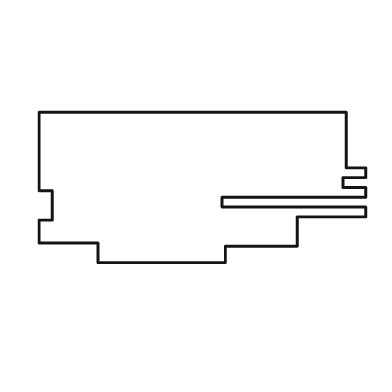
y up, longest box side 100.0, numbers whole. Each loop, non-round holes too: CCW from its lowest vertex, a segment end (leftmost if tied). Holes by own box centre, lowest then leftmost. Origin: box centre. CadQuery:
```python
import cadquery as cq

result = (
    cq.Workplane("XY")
    .moveTo(-32.0, -23.0)
    .lineTo(7.0, -23.0)
    .lineTo(7.0, -18.0)
    .lineTo(29.0, -18.0)
    .lineTo(29.0, -9.0)
    .lineTo(50.0, -9.0)
    .lineTo(50.0, -6.0)
    .lineTo(6.0, -6.0)
    .lineTo(6.0, -3.0)
    .lineTo(50.0, -3.0)
    .lineTo(50.0, 0.0)
    .lineTo(43.0, 0.0)
    .lineTo(43.0, 3.0)
    .lineTo(50.0, 3.0)
    .lineTo(50.0, 6.0)
    .lineTo(44.0, 6.0)
    .lineTo(44.0, 23.0)
    .lineTo(-50.0, 23.0)
    .lineTo(-50.0, -1.0)
    .lineTo(-46.0, -1.0)
    .lineTo(-46.0, -10.0)
    .lineTo(-50.0, -10.0)
    .lineTo(-50.0, -17.0)
    .lineTo(-32.0, -17.0)
    .close()
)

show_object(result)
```